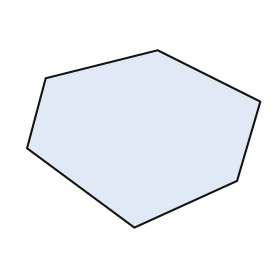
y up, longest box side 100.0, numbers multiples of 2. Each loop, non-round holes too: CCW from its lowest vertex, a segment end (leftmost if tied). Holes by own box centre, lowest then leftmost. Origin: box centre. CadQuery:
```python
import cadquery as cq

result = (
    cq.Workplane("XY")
    .moveTo(-4.0, -38.0)
    .lineTo(40.0, -18.0)
    .lineTo(50.0, 16.0)
    .lineTo(6.0, 38.0)
    .lineTo(-42.0, 26.0)
    .lineTo(-50.0, -4.0)
    .close()
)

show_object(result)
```